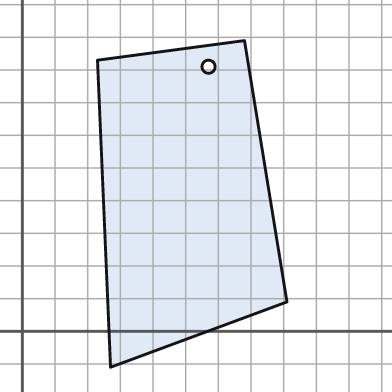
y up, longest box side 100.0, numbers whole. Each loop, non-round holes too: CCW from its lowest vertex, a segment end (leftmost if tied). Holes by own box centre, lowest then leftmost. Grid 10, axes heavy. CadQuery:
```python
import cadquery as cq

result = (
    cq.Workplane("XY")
    .moveTo(27.0, -11.0)
    .lineTo(81.0, 9.0)
    .lineTo(68.0, 89.0)
    .lineTo(23.0, 83.0)
    .close()
    .moveTo(57.0, 81.0)
    .circle(2.0)
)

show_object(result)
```